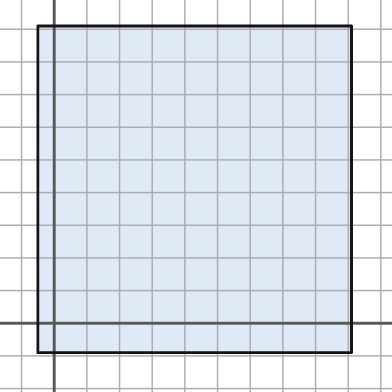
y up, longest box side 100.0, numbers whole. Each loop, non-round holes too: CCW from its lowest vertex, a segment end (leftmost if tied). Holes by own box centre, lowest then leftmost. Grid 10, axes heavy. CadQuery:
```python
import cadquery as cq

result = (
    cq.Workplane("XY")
    .moveTo(-5.0, -9.0)
    .lineTo(91.0, -9.0)
    .lineTo(91.0, 91.0)
    .lineTo(-5.0, 91.0)
    .close()
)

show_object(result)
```